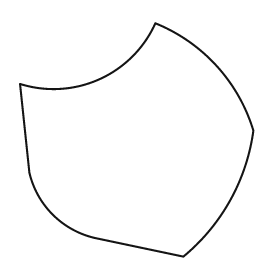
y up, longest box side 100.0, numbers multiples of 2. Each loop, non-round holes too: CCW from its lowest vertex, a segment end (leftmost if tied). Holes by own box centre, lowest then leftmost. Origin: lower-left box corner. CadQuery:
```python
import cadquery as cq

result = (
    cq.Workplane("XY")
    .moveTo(70.0, 0.0)
    .threePointArc((90.0, 24.0), (100.0, 54.0))
    .threePointArc((84.0, 82.0), (58.0, 100.0))
    .threePointArc((34.0, 76.0), (0.0, 74.0))
    .lineTo(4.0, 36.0)
    .threePointArc((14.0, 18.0), (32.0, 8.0))
    .close()
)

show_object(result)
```